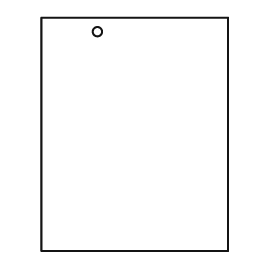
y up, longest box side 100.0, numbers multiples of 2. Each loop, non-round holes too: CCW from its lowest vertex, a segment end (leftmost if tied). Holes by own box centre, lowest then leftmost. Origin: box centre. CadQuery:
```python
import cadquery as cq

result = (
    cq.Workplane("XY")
    .moveTo(-40.0, -50.0)
    .lineTo(40.0, -50.0)
    .lineTo(40.0, 50.0)
    .lineTo(-40.0, 50.0)
    .close()
    .moveTo(-16.0, 44.0)
    .circle(2.0)
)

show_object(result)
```